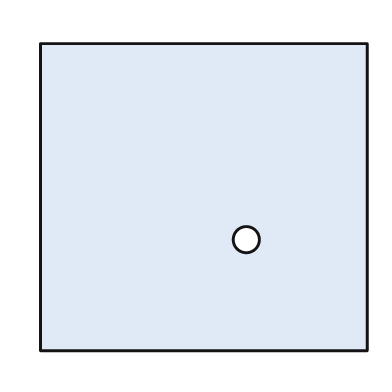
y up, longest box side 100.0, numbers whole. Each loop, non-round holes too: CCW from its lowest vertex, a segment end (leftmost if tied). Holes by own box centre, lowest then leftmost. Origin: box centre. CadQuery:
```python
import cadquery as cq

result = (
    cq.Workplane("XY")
    .moveTo(-50.0, -47.0)
    .lineTo(50.0, -47.0)
    .lineTo(50.0, 47.0)
    .lineTo(-50.0, 47.0)
    .close()
    .moveTo(13.0, -13.0)
    .circle(4.0)
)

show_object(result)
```